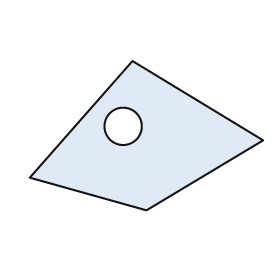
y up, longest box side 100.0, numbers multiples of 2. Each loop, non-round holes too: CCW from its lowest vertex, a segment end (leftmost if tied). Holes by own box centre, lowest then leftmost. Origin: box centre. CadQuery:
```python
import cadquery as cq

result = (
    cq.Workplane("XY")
    .moveTo(0.0, -32.0)
    .lineTo(50.0, -2.0)
    .lineTo(-6.0, 32.0)
    .lineTo(-50.0, -18.0)
    .close()
    .moveTo(-10.0, 4.0)
    .circle(8.0)
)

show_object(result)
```